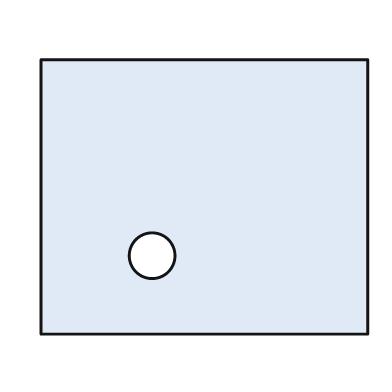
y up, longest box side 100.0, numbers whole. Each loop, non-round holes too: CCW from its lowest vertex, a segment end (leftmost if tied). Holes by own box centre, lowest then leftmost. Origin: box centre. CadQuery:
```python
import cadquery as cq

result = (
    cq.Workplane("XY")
    .moveTo(-50.0, -42.0)
    .lineTo(50.0, -42.0)
    .lineTo(50.0, 42.0)
    .lineTo(-50.0, 42.0)
    .close()
    .moveTo(-16.0, -18.0)
    .circle(7.0)
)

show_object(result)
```